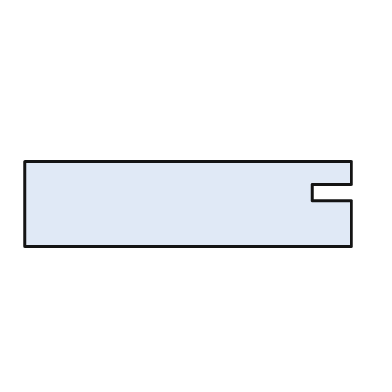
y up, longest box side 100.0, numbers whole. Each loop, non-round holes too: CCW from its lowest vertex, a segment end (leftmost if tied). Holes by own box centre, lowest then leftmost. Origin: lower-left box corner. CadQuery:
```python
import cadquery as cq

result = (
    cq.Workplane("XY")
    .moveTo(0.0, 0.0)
    .lineTo(100.0, 0.0)
    .lineTo(100.0, 14.0)
    .lineTo(88.0, 14.0)
    .lineTo(88.0, 19.0)
    .lineTo(100.0, 19.0)
    .lineTo(100.0, 26.0)
    .lineTo(0.0, 26.0)
    .close()
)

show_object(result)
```